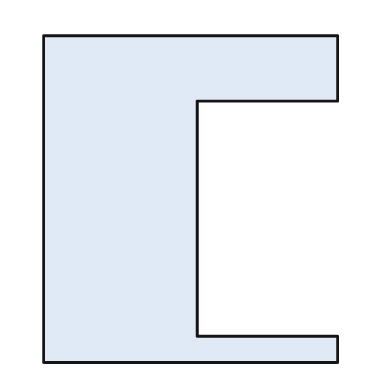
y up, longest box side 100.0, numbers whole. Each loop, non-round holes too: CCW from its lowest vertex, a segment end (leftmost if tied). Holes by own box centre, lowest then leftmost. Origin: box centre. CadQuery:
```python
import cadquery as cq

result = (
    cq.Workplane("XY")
    .moveTo(-45.0, -50.0)
    .lineTo(45.0, -50.0)
    .lineTo(45.0, -42.0)
    .lineTo(2.0, -42.0)
    .lineTo(2.0, 30.0)
    .lineTo(45.0, 30.0)
    .lineTo(45.0, 50.0)
    .lineTo(-45.0, 50.0)
    .close()
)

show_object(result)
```